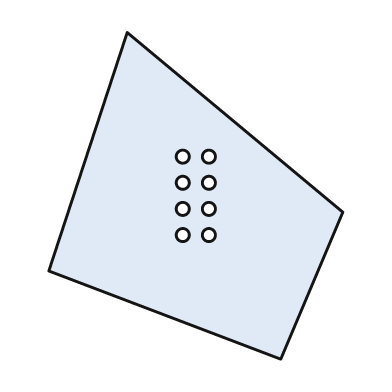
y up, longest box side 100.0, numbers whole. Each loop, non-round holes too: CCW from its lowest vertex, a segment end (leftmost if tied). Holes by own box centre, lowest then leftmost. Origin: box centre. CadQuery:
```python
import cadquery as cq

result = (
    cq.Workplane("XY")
    .moveTo(26.0, -50.0)
    .lineTo(45.0, -5.0)
    .lineTo(-21.0, 50.0)
    .lineTo(-45.0, -23.0)
    .close()
    .moveTo(-4.0, -12.0)
    .circle(2.0)
    .moveTo(4.0, -12.0)
    .circle(2.0)
    .moveTo(-4.0, -4.0)
    .circle(2.0)
    .moveTo(4.0, -4.0)
    .circle(2.0)
    .moveTo(-4.0, 4.0)
    .circle(2.0)
    .moveTo(4.0, 4.0)
    .circle(2.0)
    .moveTo(-4.0, 12.0)
    .circle(2.0)
    .moveTo(4.0, 12.0)
    .circle(2.0)
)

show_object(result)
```